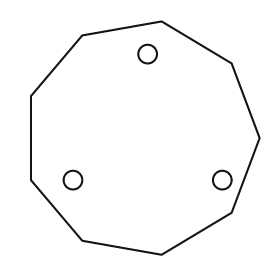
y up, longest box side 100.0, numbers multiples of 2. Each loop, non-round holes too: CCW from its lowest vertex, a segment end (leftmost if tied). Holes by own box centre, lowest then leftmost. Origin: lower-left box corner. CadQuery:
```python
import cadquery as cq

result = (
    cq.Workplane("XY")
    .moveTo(56.0, 0.0)
    .lineTo(86.0, 18.0)
    .lineTo(98.0, 50.0)
    .lineTo(86.0, 82.0)
    .lineTo(56.0, 100.0)
    .lineTo(22.0, 94.0)
    .lineTo(0.0, 68.0)
    .lineTo(0.0, 32.0)
    .lineTo(22.0, 6.0)
    .close()
    .moveTo(18.0, 32.0)
    .circle(4.0)
    .moveTo(82.0, 32.0)
    .circle(4.0)
    .moveTo(50.0, 86.0)
    .circle(4.0)
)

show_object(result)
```